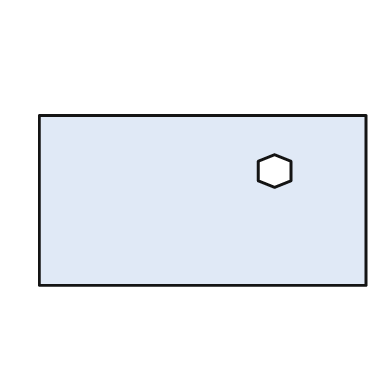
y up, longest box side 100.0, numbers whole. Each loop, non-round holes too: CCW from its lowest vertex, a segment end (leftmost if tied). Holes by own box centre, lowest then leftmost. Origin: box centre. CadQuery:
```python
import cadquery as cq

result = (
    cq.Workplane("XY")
    .moveTo(-50.0, -26.0)
    .lineTo(50.0, -26.0)
    .lineTo(50.0, 26.0)
    .lineTo(-50.0, 26.0)
    .close()
    .moveTo(22.0, 4.0)
    .lineTo(27.0, 6.0)
    .lineTo(27.0, 12.0)
    .lineTo(22.0, 14.0)
    .lineTo(17.0, 12.0)
    .lineTo(17.0, 6.0)
    .close()
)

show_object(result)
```